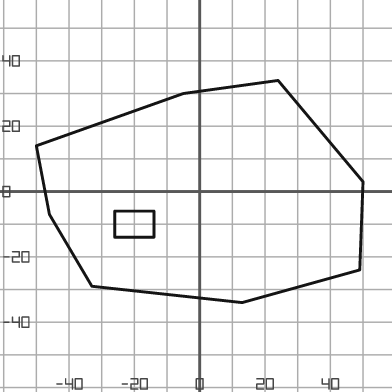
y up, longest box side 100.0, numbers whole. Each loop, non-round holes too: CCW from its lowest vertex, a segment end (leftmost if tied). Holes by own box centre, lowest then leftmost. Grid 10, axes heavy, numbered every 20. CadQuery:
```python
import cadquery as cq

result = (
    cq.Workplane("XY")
    .moveTo(13.0, -34.0)
    .lineTo(49.0, -24.0)
    .lineTo(50.0, 3.0)
    .lineTo(24.0, 34.0)
    .lineTo(-5.0, 30.0)
    .lineTo(-50.0, 14.0)
    .lineTo(-46.0, -7.0)
    .lineTo(-33.0, -29.0)
    .close()
    .moveTo(-26.0, -14.0)
    .lineTo(-14.0, -14.0)
    .lineTo(-14.0, -6.0)
    .lineTo(-26.0, -6.0)
    .close()
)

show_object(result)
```